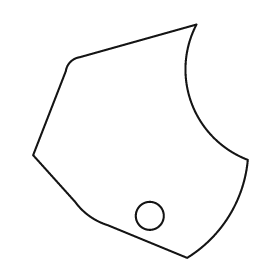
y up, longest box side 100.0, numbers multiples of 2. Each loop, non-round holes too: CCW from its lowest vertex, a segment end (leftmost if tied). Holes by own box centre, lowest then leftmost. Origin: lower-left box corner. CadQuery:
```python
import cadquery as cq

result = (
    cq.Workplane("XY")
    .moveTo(66.0, 0.0)
    .threePointArc((84.0, 18.0), (92.0, 42.0))
    .threePointArc((68.0, 66.0), (70.0, 100.0))
    .lineTo(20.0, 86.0)
    .threePointArc((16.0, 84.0), (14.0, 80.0))
    .lineTo(0.0, 44.0)
    .lineTo(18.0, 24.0)
    .threePointArc((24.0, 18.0), (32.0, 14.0))
    .close()
    .moveTo(50.0, 18.0)
    .circle(6.0)
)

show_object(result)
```